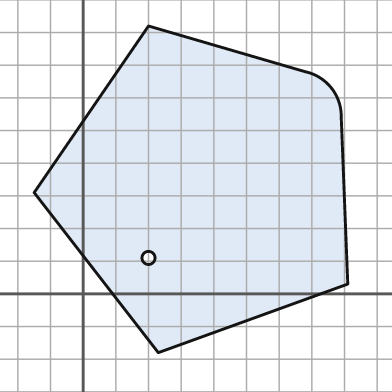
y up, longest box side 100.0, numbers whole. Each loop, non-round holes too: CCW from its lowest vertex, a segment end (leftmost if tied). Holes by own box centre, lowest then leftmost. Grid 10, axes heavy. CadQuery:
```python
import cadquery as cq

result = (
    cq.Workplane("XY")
    .moveTo(23.0, -18.0)
    .lineTo(81.0, 3.0)
    .lineTo(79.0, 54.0)
    .threePointArc((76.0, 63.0), (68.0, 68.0))
    .lineTo(20.0, 82.0)
    .lineTo(-15.0, 31.0)
    .close()
    .moveTo(20.0, 11.0)
    .circle(2.0)
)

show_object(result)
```